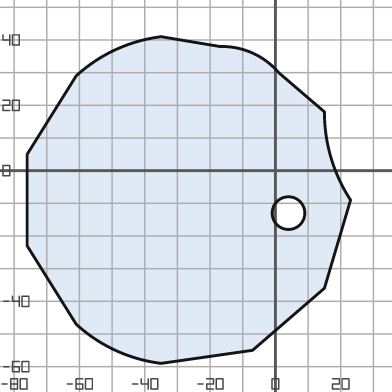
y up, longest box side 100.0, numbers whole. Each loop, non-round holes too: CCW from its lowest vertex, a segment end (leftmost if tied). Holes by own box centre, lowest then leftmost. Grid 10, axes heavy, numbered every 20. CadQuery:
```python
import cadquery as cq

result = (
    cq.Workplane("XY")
    .moveTo(-35.0, -59.0)
    .lineTo(-7.0, -55.0)
    .lineTo(15.0, -36.0)
    .lineTo(23.0, -9.0)
    .threePointArc((17.0, 4.0), (15.0, 18.0))
    .lineTo(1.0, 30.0)
    .threePointArc((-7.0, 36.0), (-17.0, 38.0))
    .lineTo(-35.0, 41.0)
    .threePointArc((-49.0, 37.0), (-61.0, 29.0))
    .lineTo(-76.0, 5.0)
    .lineTo(-76.0, -23.0)
    .lineTo(-61.0, -47.0)
    .threePointArc((-49.0, -55.0), (-35.0, -59.0))
    .close()
    .moveTo(4.0, -13.0)
    .circle(5.0)
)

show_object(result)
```